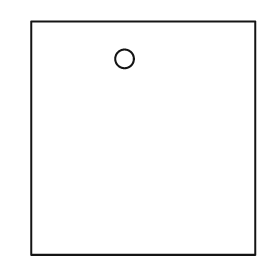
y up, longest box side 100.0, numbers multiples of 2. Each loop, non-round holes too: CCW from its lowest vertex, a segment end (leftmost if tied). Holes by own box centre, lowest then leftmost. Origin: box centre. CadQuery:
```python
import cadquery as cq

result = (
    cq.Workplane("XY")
    .moveTo(-48.0, -50.0)
    .lineTo(48.0, -50.0)
    .lineTo(48.0, 50.0)
    .lineTo(-48.0, 50.0)
    .close()
    .moveTo(-8.0, 34.0)
    .circle(4.0)
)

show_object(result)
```